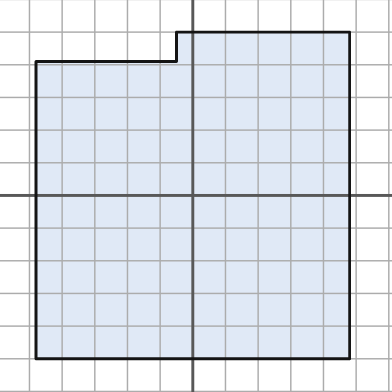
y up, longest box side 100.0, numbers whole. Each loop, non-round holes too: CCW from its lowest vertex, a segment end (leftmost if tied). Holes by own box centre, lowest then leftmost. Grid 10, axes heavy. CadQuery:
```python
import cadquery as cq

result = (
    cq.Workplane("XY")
    .moveTo(-48.0, -50.0)
    .lineTo(48.0, -50.0)
    .lineTo(48.0, 50.0)
    .lineTo(-5.0, 50.0)
    .lineTo(-5.0, 41.0)
    .lineTo(-48.0, 41.0)
    .close()
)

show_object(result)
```